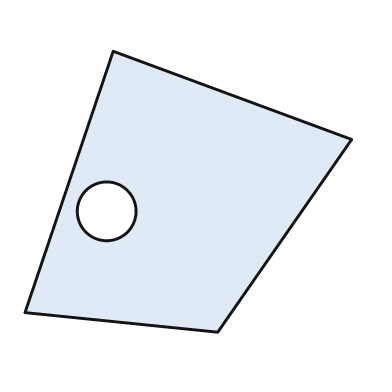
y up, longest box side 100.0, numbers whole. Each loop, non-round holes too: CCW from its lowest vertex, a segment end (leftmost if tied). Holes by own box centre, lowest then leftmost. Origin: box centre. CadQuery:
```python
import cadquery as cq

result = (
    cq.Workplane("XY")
    .moveTo(9.0, -43.0)
    .lineTo(50.0, 16.0)
    .lineTo(-23.0, 43.0)
    .lineTo(-50.0, -37.0)
    .close()
    .moveTo(-25.0, -6.0)
    .circle(9.0)
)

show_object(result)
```